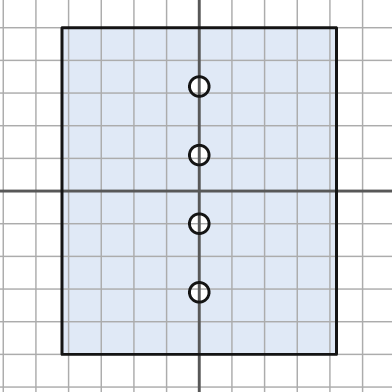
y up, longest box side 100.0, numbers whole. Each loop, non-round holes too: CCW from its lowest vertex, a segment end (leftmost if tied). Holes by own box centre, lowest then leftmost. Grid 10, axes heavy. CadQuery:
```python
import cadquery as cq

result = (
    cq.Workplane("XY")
    .moveTo(-42.0, -50.0)
    .lineTo(42.0, -50.0)
    .lineTo(42.0, 50.0)
    .lineTo(-42.0, 50.0)
    .close()
    .moveTo(0.0, -31.0)
    .circle(3.0)
    .moveTo(0.0, -10.0)
    .circle(3.0)
    .moveTo(0.0, 11.0)
    .circle(3.0)
    .moveTo(0.0, 32.0)
    .circle(3.0)
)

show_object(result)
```